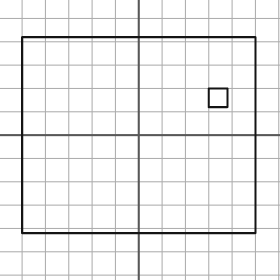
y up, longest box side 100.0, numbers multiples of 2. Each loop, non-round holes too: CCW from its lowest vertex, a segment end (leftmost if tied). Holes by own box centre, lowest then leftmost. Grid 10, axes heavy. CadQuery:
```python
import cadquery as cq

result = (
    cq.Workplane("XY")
    .moveTo(-50.0, -42.0)
    .lineTo(50.0, -42.0)
    .lineTo(50.0, 42.0)
    .lineTo(-50.0, 42.0)
    .close()
    .moveTo(30.0, 12.0)
    .lineTo(38.0, 12.0)
    .lineTo(38.0, 20.0)
    .lineTo(30.0, 20.0)
    .close()
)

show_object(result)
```